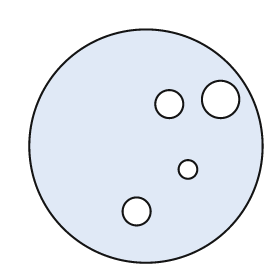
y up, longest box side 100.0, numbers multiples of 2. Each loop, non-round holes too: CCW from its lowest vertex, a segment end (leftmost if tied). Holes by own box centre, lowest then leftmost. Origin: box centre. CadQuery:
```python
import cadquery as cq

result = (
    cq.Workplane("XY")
    .moveTo(0.0, 0.0)
    .circle(50.0)
    .moveTo(-4.0, -28.0)
    .circle(6.0)
    .moveTo(18.0, -10.0)
    .circle(4.0)
    .moveTo(10.0, 18.0)
    .circle(6.0)
    .moveTo(32.0, 20.0)
    .circle(8.0)
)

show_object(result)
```